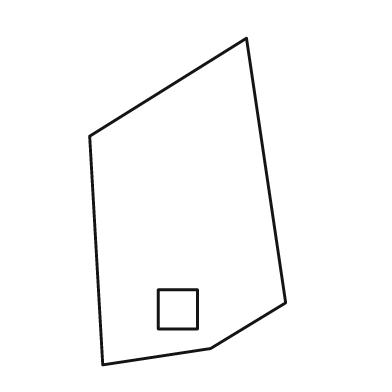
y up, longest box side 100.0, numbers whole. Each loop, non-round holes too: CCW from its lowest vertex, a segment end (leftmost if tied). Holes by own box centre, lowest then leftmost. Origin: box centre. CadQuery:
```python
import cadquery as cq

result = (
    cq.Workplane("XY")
    .moveTo(-26.0, -50.0)
    .lineTo(7.0, -45.0)
    .lineTo(30.0, -31.0)
    .lineTo(18.0, 50.0)
    .lineTo(-30.0, 20.0)
    .close()
    .moveTo(-9.0, -39.0)
    .lineTo(3.0, -39.0)
    .lineTo(3.0, -27.0)
    .lineTo(-9.0, -27.0)
    .close()
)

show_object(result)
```